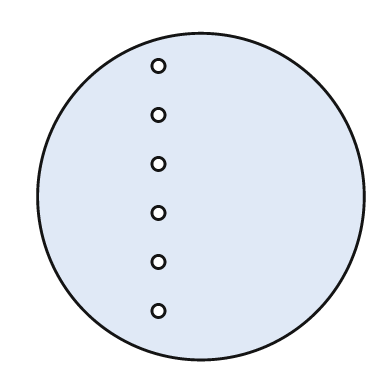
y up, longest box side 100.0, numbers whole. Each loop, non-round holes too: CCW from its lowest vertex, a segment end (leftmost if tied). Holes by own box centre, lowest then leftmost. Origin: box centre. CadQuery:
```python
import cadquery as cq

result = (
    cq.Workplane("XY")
    .moveTo(0.0, 0.0)
    .circle(50.0)
    .moveTo(-13.0, -35.0)
    .circle(2.0)
    .moveTo(-13.0, -20.0)
    .circle(2.0)
    .moveTo(-13.0, -5.0)
    .circle(2.0)
    .moveTo(-13.0, 10.0)
    .circle(2.0)
    .moveTo(-13.0, 25.0)
    .circle(2.0)
    .moveTo(-13.0, 40.0)
    .circle(2.0)
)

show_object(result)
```